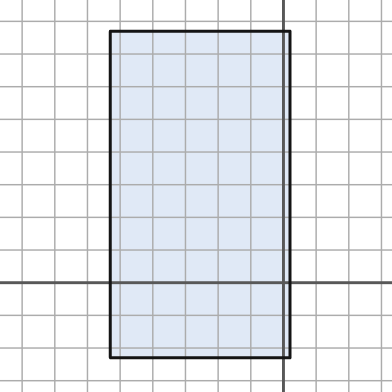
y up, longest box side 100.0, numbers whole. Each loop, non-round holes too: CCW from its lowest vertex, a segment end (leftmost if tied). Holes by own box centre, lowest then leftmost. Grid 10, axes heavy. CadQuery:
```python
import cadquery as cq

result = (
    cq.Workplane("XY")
    .moveTo(-53.0, -23.0)
    .lineTo(2.0, -23.0)
    .lineTo(2.0, 77.0)
    .lineTo(-53.0, 77.0)
    .close()
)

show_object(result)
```